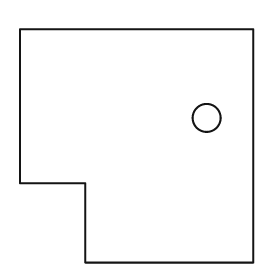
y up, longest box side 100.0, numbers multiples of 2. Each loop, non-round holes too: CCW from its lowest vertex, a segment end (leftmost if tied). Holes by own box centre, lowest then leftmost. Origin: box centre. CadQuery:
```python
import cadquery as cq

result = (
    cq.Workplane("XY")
    .moveTo(-22.0, -50.0)
    .lineTo(50.0, -50.0)
    .lineTo(50.0, 50.0)
    .lineTo(-50.0, 50.0)
    .lineTo(-50.0, -16.0)
    .lineTo(-22.0, -16.0)
    .close()
    .moveTo(30.0, 12.0)
    .circle(6.0)
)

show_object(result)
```